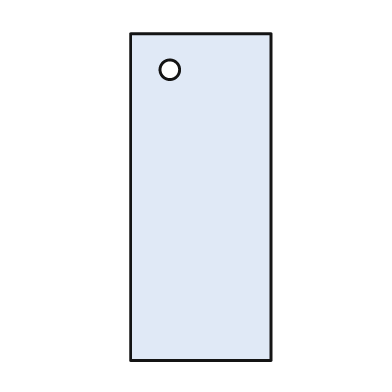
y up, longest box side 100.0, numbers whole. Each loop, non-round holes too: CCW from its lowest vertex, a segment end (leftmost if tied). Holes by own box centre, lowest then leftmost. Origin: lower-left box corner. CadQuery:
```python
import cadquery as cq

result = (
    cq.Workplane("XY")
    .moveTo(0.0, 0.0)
    .lineTo(43.0, 0.0)
    .lineTo(43.0, 100.0)
    .lineTo(0.0, 100.0)
    .close()
    .moveTo(12.0, 89.0)
    .circle(3.0)
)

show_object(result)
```